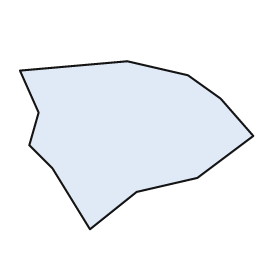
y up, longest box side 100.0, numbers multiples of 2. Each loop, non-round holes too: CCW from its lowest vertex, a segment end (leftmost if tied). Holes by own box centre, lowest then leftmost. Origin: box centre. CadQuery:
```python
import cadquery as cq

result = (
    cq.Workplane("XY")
    .moveTo(-20.0, -36.0)
    .lineTo(0.0, -20.0)
    .lineTo(26.0, -14.0)
    .lineTo(50.0, 4.0)
    .lineTo(36.0, 20.0)
    .lineTo(22.0, 30.0)
    .lineTo(-4.0, 36.0)
    .lineTo(-50.0, 32.0)
    .lineTo(-42.0, 14.0)
    .lineTo(-46.0, 0.0)
    .lineTo(-36.0, -10.0)
    .close()
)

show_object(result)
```